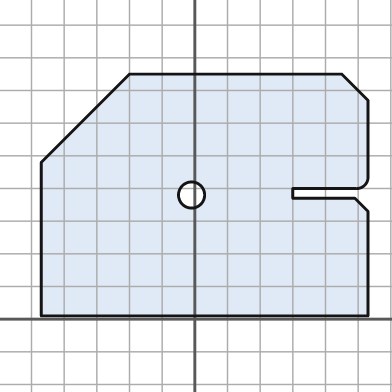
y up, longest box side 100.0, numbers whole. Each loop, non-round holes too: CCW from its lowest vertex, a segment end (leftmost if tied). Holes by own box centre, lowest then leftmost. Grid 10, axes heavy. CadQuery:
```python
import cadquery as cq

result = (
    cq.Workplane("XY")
    .moveTo(-47.0, 1.0)
    .lineTo(53.0, 1.0)
    .lineTo(53.0, 33.0)
    .lineTo(49.0, 37.0)
    .lineTo(30.0, 37.0)
    .lineTo(30.0, 40.0)
    .lineTo(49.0, 40.0)
    .threePointArc((52.0, 41.0), (53.0, 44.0))
    .lineTo(53.0, 67.0)
    .lineTo(45.0, 75.0)
    .lineTo(-20.0, 75.0)
    .lineTo(-47.0, 48.0)
    .close()
    .moveTo(-1.0, 38.0)
    .circle(4.0)
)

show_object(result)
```